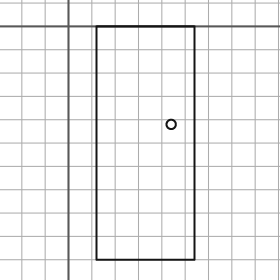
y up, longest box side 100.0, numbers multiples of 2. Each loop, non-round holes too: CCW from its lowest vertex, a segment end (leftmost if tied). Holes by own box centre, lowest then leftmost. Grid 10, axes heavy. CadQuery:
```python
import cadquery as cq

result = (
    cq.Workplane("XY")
    .moveTo(12.0, -100.0)
    .lineTo(54.0, -100.0)
    .lineTo(54.0, 0.0)
    .lineTo(12.0, 0.0)
    .close()
    .moveTo(44.0, -42.0)
    .circle(2.0)
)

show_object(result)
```